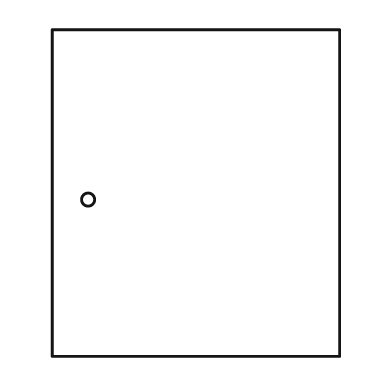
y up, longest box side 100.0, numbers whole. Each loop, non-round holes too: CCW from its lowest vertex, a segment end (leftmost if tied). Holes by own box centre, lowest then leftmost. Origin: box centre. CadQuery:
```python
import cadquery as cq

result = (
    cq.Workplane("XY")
    .moveTo(-44.0, -50.0)
    .lineTo(44.0, -50.0)
    .lineTo(44.0, 50.0)
    .lineTo(-44.0, 50.0)
    .close()
    .moveTo(-33.0, -2.0)
    .circle(2.0)
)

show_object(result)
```